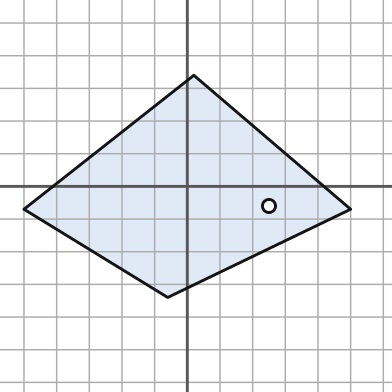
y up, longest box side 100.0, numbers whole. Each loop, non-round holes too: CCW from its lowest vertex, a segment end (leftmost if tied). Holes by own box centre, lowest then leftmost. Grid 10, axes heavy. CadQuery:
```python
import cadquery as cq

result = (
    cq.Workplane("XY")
    .moveTo(-6.0, -34.0)
    .lineTo(50.0, -7.0)
    .lineTo(2.0, 34.0)
    .lineTo(-50.0, -7.0)
    .close()
    .moveTo(25.0, -6.0)
    .circle(2.0)
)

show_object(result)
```